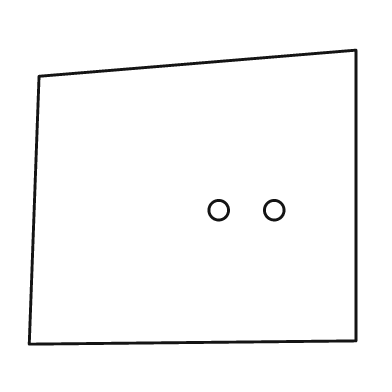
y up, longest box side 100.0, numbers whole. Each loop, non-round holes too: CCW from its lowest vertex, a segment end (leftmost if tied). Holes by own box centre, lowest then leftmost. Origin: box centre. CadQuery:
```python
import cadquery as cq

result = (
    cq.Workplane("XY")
    .moveTo(-50.0, -45.0)
    .lineTo(50.0, -44.0)
    .lineTo(50.0, 45.0)
    .lineTo(-47.0, 37.0)
    .close()
    .moveTo(8.0, -4.0)
    .circle(3.0)
    .moveTo(25.0, -4.0)
    .circle(3.0)
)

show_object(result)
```